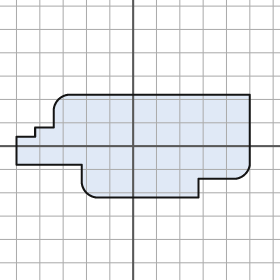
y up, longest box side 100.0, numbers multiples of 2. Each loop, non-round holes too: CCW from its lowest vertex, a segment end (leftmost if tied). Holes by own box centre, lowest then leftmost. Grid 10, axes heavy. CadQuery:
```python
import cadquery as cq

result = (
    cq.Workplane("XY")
    .moveTo(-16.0, -22.0)
    .lineTo(28.0, -22.0)
    .lineTo(28.0, -14.0)
    .lineTo(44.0, -14.0)
    .threePointArc((48.0, -12.0), (50.0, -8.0))
    .lineTo(50.0, 22.0)
    .lineTo(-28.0, 22.0)
    .threePointArc((-32.0, 20.0), (-34.0, 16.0))
    .lineTo(-34.0, 8.0)
    .lineTo(-42.0, 8.0)
    .lineTo(-42.0, 4.0)
    .lineTo(-50.0, 4.0)
    .lineTo(-50.0, -8.0)
    .lineTo(-22.0, -8.0)
    .lineTo(-22.0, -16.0)
    .threePointArc((-20.0, -20.0), (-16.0, -22.0))
    .close()
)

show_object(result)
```